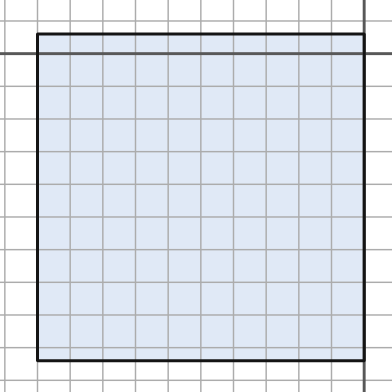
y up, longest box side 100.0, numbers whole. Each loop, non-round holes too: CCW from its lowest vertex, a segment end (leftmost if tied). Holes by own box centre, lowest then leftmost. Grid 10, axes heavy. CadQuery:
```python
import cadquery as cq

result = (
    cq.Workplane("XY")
    .moveTo(-100.0, -94.0)
    .lineTo(0.0, -94.0)
    .lineTo(0.0, 6.0)
    .lineTo(-100.0, 6.0)
    .close()
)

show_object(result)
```